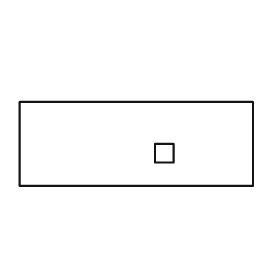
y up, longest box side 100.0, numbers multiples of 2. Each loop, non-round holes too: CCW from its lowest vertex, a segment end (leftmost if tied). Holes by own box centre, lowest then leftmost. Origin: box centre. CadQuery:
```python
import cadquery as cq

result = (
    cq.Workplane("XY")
    .moveTo(-50.0, -18.0)
    .lineTo(50.0, -18.0)
    .lineTo(50.0, 18.0)
    .lineTo(-50.0, 18.0)
    .close()
    .moveTo(8.0, -8.0)
    .lineTo(16.0, -8.0)
    .lineTo(16.0, 0.0)
    .lineTo(8.0, 0.0)
    .close()
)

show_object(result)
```